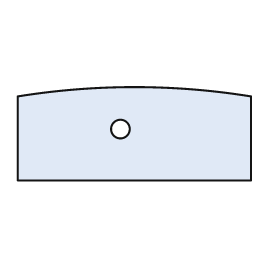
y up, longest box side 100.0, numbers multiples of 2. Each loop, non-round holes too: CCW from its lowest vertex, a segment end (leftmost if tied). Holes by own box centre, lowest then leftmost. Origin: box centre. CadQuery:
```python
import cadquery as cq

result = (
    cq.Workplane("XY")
    .moveTo(-50.0, -20.0)
    .lineTo(50.0, -20.0)
    .lineTo(50.0, 16.0)
    .threePointArc((0.0, 20.0), (-50.0, 16.0))
    .close()
    .moveTo(-6.0, 2.0)
    .circle(4.0)
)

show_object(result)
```